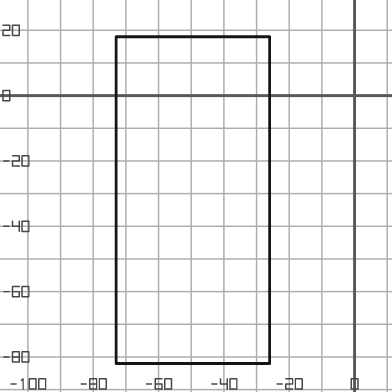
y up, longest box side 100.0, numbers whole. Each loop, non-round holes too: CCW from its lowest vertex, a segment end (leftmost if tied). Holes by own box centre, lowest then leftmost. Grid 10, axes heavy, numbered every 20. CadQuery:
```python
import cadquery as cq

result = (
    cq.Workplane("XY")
    .moveTo(-73.0, -82.0)
    .lineTo(-26.0, -82.0)
    .lineTo(-26.0, 18.0)
    .lineTo(-73.0, 18.0)
    .close()
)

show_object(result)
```